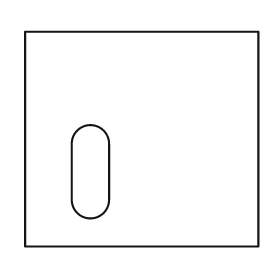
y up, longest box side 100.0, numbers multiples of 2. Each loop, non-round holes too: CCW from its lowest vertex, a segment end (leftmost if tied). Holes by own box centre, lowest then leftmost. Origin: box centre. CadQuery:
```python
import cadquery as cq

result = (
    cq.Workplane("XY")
    .moveTo(-50.0, -46.0)
    .lineTo(50.0, -46.0)
    .lineTo(50.0, 46.0)
    .lineTo(-50.0, 46.0)
    .close()
    .moveTo(-30.0, -26.0)
    .threePointArc((-22.0, -34.0), (-14.0, -26.0))
    .lineTo(-14.0, -2.0)
    .threePointArc((-22.0, 6.0), (-30.0, -2.0))
    .close()
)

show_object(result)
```